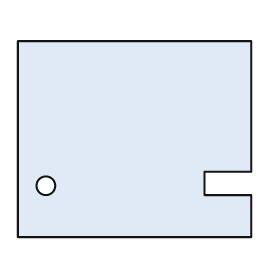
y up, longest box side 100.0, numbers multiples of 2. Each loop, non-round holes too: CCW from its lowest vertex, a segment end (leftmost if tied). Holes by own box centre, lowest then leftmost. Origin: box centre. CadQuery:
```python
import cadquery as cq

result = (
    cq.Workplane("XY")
    .moveTo(-50.0, -42.0)
    .lineTo(50.0, -42.0)
    .lineTo(50.0, -24.0)
    .lineTo(30.0, -24.0)
    .lineTo(30.0, -14.0)
    .lineTo(50.0, -14.0)
    .lineTo(50.0, 42.0)
    .lineTo(-50.0, 42.0)
    .close()
    .moveTo(-38.0, -20.0)
    .circle(4.0)
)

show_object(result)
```